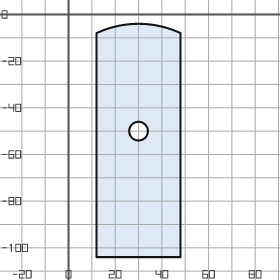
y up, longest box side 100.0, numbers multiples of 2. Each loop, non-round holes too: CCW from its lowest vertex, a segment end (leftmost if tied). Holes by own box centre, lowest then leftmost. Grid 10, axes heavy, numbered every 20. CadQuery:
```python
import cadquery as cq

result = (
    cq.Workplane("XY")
    .moveTo(12.0, -104.0)
    .lineTo(48.0, -104.0)
    .lineTo(48.0, -8.0)
    .threePointArc((30.0, -4.0), (12.0, -8.0))
    .close()
    .moveTo(30.0, -50.0)
    .circle(4.0)
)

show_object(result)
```